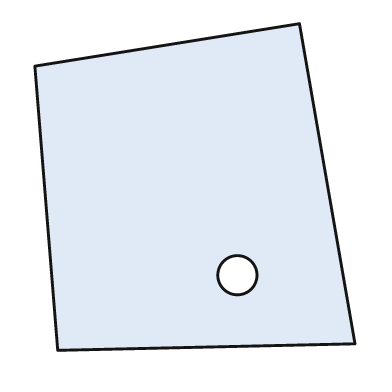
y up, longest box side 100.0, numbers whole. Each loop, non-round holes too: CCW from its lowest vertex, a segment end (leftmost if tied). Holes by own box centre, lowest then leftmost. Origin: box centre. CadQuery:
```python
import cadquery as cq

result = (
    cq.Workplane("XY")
    .moveTo(-42.0, -50.0)
    .lineTo(49.0, -48.0)
    .lineTo(32.0, 50.0)
    .lineTo(-49.0, 37.0)
    .close()
    .moveTo(13.0, -27.0)
    .circle(6.0)
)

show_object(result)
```